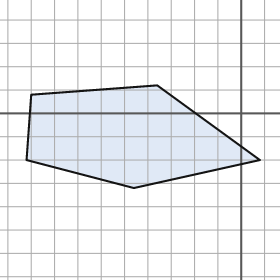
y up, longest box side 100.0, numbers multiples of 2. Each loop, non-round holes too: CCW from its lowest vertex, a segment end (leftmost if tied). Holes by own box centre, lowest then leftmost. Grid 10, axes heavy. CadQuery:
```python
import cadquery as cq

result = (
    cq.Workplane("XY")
    .moveTo(-46.0, -32.0)
    .lineTo(8.0, -20.0)
    .lineTo(-36.0, 12.0)
    .lineTo(-90.0, 8.0)
    .lineTo(-92.0, -20.0)
    .close()
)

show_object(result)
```